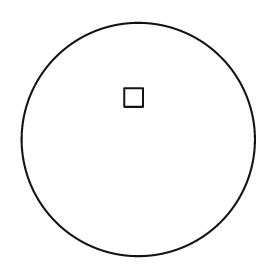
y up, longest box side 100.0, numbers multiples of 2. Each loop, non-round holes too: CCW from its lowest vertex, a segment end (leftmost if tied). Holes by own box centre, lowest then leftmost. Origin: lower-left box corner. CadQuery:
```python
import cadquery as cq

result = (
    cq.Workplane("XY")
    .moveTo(50.0, 50.0)
    .circle(50.0)
    .moveTo(44.0, 64.0)
    .lineTo(52.0, 64.0)
    .lineTo(52.0, 72.0)
    .lineTo(44.0, 72.0)
    .close()
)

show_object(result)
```